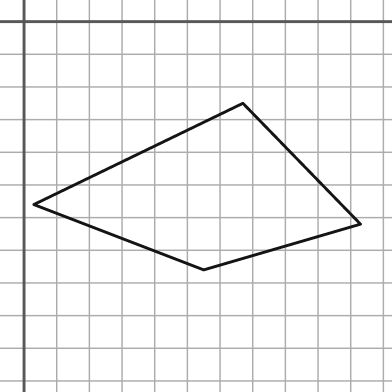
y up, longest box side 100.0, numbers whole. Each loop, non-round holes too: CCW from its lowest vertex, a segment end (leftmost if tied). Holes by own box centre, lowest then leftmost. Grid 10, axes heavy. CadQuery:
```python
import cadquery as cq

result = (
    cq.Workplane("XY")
    .moveTo(55.0, -76.0)
    .lineTo(103.0, -62.0)
    .lineTo(67.0, -25.0)
    .lineTo(3.0, -56.0)
    .close()
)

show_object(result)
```